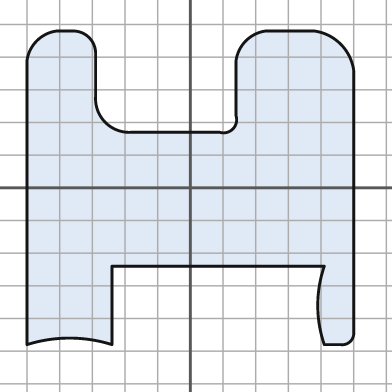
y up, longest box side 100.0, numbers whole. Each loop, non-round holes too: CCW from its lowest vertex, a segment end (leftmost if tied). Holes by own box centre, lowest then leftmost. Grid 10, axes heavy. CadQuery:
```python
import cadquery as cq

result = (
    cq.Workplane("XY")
    .moveTo(-50.0, -48.0)
    .threePointArc((-37.0, -46.0), (-24.0, -48.0))
    .lineTo(-24.0, -24.0)
    .lineTo(41.0, -24.0)
    .threePointArc((39.0, -36.0), (41.0, -48.0))
    .lineTo(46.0, -48.0)
    .threePointArc((49.0, -47.0), (50.0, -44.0))
    .lineTo(50.0, 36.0)
    .threePointArc((46.0, 44.0), (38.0, 48.0))
    .lineTo(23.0, 48.0)
    .threePointArc((17.0, 45.0), (14.0, 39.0))
    .lineTo(14.0, 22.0)
    .threePointArc((13.0, 18.0), (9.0, 17.0))
    .lineTo(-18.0, 17.0)
    .threePointArc((-26.0, 20.0), (-29.0, 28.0))
    .lineTo(-29.0, 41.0)
    .threePointArc((-31.0, 46.0), (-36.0, 48.0))
    .lineTo(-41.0, 48.0)
    .threePointArc((-47.0, 45.0), (-50.0, 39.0))
    .close()
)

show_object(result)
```